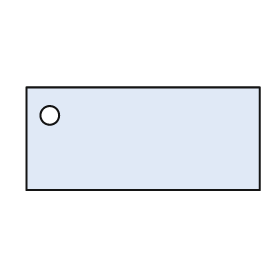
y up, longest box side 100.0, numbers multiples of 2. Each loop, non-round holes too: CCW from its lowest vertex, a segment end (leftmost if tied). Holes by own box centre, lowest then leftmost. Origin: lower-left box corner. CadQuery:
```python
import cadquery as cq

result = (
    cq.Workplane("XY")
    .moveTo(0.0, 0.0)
    .lineTo(100.0, 0.0)
    .lineTo(100.0, 44.0)
    .lineTo(0.0, 44.0)
    .close()
    .moveTo(10.0, 32.0)
    .circle(4.0)
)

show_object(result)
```